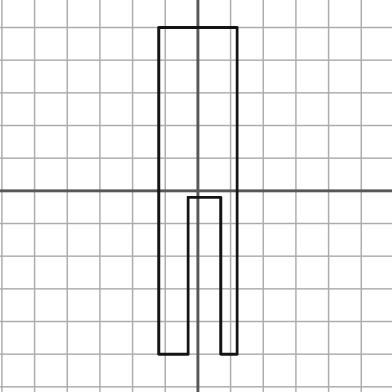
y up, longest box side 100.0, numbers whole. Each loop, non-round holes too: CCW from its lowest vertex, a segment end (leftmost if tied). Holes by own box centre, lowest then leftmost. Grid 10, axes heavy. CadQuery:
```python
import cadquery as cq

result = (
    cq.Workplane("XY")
    .moveTo(-12.0, -50.0)
    .lineTo(-3.0, -50.0)
    .lineTo(-3.0, -2.0)
    .lineTo(7.0, -2.0)
    .lineTo(7.0, -50.0)
    .lineTo(12.0, -50.0)
    .lineTo(12.0, 50.0)
    .lineTo(-12.0, 50.0)
    .close()
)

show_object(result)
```